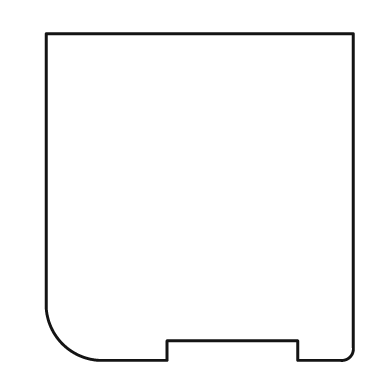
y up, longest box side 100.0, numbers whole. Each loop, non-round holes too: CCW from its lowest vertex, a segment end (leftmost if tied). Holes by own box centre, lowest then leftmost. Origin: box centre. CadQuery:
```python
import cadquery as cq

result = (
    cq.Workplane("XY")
    .moveTo(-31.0, -50.0)
    .lineTo(-10.0, -50.0)
    .lineTo(-10.0, -44.0)
    .lineTo(30.0, -44.0)
    .lineTo(30.0, -50.0)
    .lineTo(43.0, -50.0)
    .threePointArc((46.0, -49.0), (47.0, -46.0))
    .lineTo(47.0, 50.0)
    .lineTo(-47.0, 50.0)
    .lineTo(-47.0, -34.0)
    .threePointArc((-42.0, -45.0), (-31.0, -50.0))
    .close()
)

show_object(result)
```